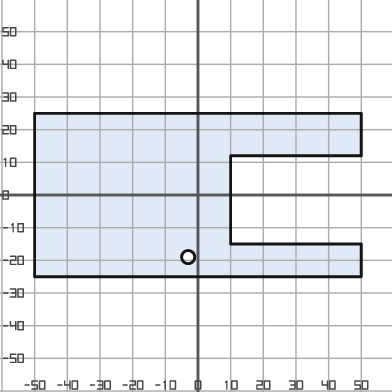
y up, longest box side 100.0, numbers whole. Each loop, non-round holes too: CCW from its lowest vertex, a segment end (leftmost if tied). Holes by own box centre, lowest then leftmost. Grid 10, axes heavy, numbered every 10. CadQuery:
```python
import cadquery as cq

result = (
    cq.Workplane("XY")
    .moveTo(-50.0, -25.0)
    .lineTo(50.0, -25.0)
    .lineTo(50.0, -15.0)
    .lineTo(10.0, -15.0)
    .lineTo(10.0, 12.0)
    .lineTo(50.0, 12.0)
    .lineTo(50.0, 25.0)
    .lineTo(-50.0, 25.0)
    .close()
    .moveTo(-3.0, -19.0)
    .circle(2.0)
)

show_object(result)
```